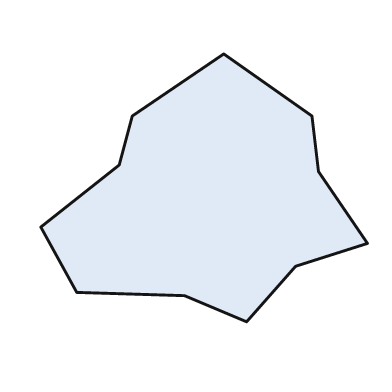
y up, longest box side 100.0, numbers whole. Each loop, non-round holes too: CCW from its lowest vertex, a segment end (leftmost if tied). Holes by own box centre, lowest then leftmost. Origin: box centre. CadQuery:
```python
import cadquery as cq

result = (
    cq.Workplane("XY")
    .moveTo(13.0, -41.0)
    .lineTo(28.0, -24.0)
    .lineTo(50.0, -17.0)
    .lineTo(35.0, 5.0)
    .lineTo(33.0, 22.0)
    .lineTo(6.0, 41.0)
    .lineTo(-22.0, 22.0)
    .lineTo(-26.0, 7.0)
    .lineTo(-50.0, -12.0)
    .lineTo(-39.0, -32.0)
    .lineTo(-6.0, -33.0)
    .close()
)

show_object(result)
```